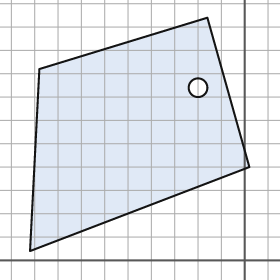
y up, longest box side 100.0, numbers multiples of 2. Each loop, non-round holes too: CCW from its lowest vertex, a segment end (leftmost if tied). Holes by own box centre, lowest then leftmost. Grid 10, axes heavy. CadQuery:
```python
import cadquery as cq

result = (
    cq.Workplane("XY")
    .moveTo(-92.0, 4.0)
    .lineTo(2.0, 40.0)
    .lineTo(-16.0, 104.0)
    .lineTo(-88.0, 82.0)
    .close()
    .moveTo(-20.0, 74.0)
    .circle(4.0)
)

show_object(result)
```